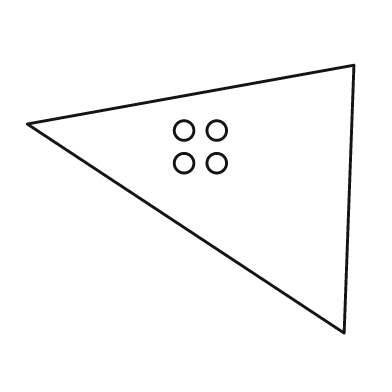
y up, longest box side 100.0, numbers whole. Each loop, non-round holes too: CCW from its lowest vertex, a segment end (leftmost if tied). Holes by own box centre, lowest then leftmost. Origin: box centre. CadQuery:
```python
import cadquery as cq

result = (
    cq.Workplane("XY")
    .moveTo(47.0, -41.0)
    .lineTo(50.0, 41.0)
    .lineTo(-50.0, 23.0)
    .close()
    .moveTo(-2.0, 11.0)
    .circle(3.0)
    .moveTo(8.0, 11.0)
    .circle(3.0)
    .moveTo(-2.0, 21.0)
    .circle(3.0)
    .moveTo(8.0, 21.0)
    .circle(3.0)
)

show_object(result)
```